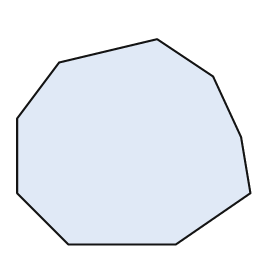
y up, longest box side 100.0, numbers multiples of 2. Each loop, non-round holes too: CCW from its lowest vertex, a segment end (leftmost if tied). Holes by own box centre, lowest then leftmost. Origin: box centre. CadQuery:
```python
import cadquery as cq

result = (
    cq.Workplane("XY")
    .moveTo(-28.0, -44.0)
    .lineTo(18.0, -44.0)
    .lineTo(50.0, -22.0)
    .lineTo(46.0, 2.0)
    .lineTo(34.0, 28.0)
    .lineTo(10.0, 44.0)
    .lineTo(-32.0, 34.0)
    .lineTo(-50.0, 10.0)
    .lineTo(-50.0, -22.0)
    .close()
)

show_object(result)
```